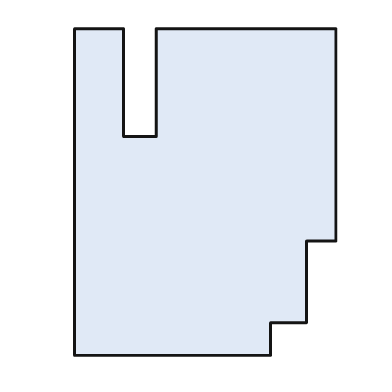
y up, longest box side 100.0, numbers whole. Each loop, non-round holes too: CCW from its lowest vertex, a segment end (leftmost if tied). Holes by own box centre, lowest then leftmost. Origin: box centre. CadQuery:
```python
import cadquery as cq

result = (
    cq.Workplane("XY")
    .moveTo(-40.0, -50.0)
    .lineTo(20.0, -50.0)
    .lineTo(20.0, -40.0)
    .lineTo(31.0, -40.0)
    .lineTo(31.0, -15.0)
    .lineTo(40.0, -15.0)
    .lineTo(40.0, 50.0)
    .lineTo(-15.0, 50.0)
    .lineTo(-15.0, 17.0)
    .lineTo(-25.0, 17.0)
    .lineTo(-25.0, 50.0)
    .lineTo(-40.0, 50.0)
    .close()
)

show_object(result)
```